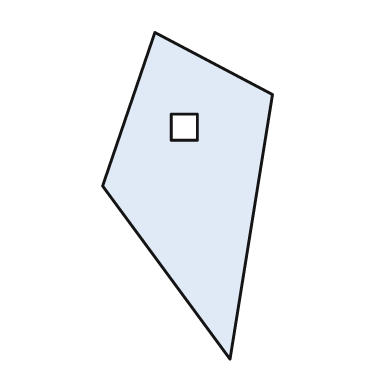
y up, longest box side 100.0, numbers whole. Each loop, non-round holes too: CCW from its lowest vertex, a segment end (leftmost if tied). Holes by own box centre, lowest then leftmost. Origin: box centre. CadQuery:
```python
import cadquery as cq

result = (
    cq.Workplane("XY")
    .moveTo(13.0, -50.0)
    .lineTo(26.0, 31.0)
    .lineTo(-10.0, 50.0)
    .lineTo(-26.0, 3.0)
    .close()
    .moveTo(-5.0, 17.0)
    .lineTo(3.0, 17.0)
    .lineTo(3.0, 25.0)
    .lineTo(-5.0, 25.0)
    .close()
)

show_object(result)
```